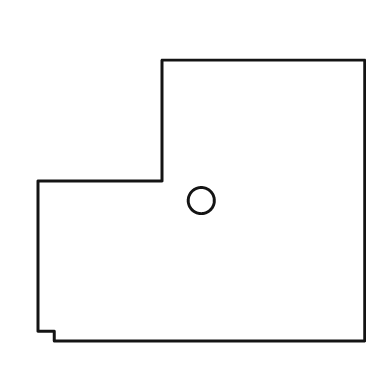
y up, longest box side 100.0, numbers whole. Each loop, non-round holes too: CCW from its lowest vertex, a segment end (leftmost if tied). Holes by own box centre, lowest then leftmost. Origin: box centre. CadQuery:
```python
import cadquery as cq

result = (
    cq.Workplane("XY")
    .moveTo(-45.0, -43.0)
    .lineTo(50.0, -43.0)
    .lineTo(50.0, 43.0)
    .lineTo(-12.0, 43.0)
    .lineTo(-12.0, 6.0)
    .lineTo(-50.0, 6.0)
    .lineTo(-50.0, -40.0)
    .lineTo(-45.0, -40.0)
    .close()
    .moveTo(0.0, 0.0)
    .circle(4.0)
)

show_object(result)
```